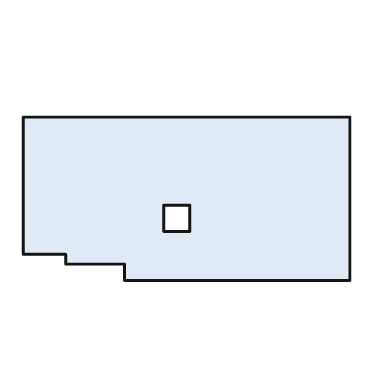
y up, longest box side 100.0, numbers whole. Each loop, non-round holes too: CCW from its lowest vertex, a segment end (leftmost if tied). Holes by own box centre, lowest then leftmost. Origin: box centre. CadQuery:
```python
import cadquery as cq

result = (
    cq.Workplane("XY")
    .moveTo(-19.0, -25.0)
    .lineTo(50.0, -25.0)
    .lineTo(50.0, 25.0)
    .lineTo(-50.0, 25.0)
    .lineTo(-50.0, -17.0)
    .lineTo(-37.0, -17.0)
    .lineTo(-37.0, -20.0)
    .lineTo(-19.0, -20.0)
    .close()
    .moveTo(-7.0, -10.0)
    .lineTo(1.0, -10.0)
    .lineTo(1.0, -2.0)
    .lineTo(-7.0, -2.0)
    .close()
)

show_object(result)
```